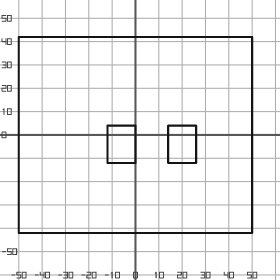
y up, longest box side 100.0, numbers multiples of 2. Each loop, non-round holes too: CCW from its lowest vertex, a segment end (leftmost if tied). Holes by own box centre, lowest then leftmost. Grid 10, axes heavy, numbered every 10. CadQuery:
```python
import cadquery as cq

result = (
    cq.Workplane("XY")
    .moveTo(-50.0, -42.0)
    .lineTo(50.0, -42.0)
    .lineTo(50.0, 42.0)
    .lineTo(-50.0, 42.0)
    .close()
    .moveTo(-12.0, -12.0)
    .lineTo(0.0, -12.0)
    .lineTo(0.0, 4.0)
    .lineTo(-12.0, 4.0)
    .close()
    .moveTo(14.0, -12.0)
    .lineTo(26.0, -12.0)
    .lineTo(26.0, 4.0)
    .lineTo(14.0, 4.0)
    .close()
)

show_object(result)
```